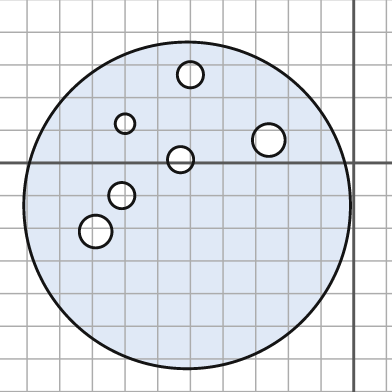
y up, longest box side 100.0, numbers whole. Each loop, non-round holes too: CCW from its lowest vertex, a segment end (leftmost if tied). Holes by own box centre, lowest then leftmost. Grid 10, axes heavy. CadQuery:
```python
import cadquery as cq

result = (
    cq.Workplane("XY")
    .moveTo(-51.0, -13.0)
    .circle(50.0)
    .moveTo(-79.0, -21.0)
    .circle(5.0)
    .moveTo(-71.0, -10.0)
    .circle(4.0)
    .moveTo(-53.0, 1.0)
    .circle(4.0)
    .moveTo(-26.0, 7.0)
    .circle(5.0)
    .moveTo(-70.0, 12.0)
    .circle(3.0)
    .moveTo(-50.0, 27.0)
    .circle(4.0)
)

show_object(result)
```